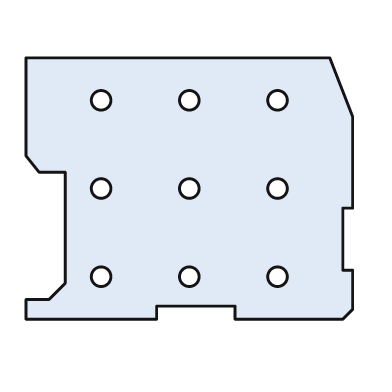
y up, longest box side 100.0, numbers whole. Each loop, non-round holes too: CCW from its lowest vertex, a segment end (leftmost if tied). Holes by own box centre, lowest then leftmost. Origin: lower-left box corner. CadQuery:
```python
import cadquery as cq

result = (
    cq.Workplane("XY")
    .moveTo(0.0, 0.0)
    .lineTo(40.0, 0.0)
    .lineTo(40.0, 4.0)
    .lineTo(64.0, 4.0)
    .lineTo(64.0, 0.0)
    .lineTo(97.0, 0.0)
    .lineTo(100.0, 3.0)
    .lineTo(100.0, 15.0)
    .lineTo(97.0, 15.0)
    .lineTo(97.0, 34.0)
    .lineTo(100.0, 34.0)
    .lineTo(100.0, 62.0)
    .lineTo(93.0, 80.0)
    .lineTo(0.0, 80.0)
    .lineTo(0.0, 50.0)
    .lineTo(4.0, 45.0)
    .lineTo(12.0, 45.0)
    .lineTo(12.0, 11.0)
    .lineTo(7.0, 6.0)
    .lineTo(0.0, 6.0)
    .close()
    .moveTo(23.0, 13.0)
    .circle(3.0)
    .moveTo(50.0, 13.0)
    .circle(3.0)
    .moveTo(77.0, 13.0)
    .circle(3.0)
    .moveTo(23.0, 40.0)
    .circle(3.0)
    .moveTo(50.0, 40.0)
    .circle(3.0)
    .moveTo(77.0, 40.0)
    .circle(3.0)
    .moveTo(23.0, 67.0)
    .circle(3.0)
    .moveTo(50.0, 67.0)
    .circle(3.0)
    .moveTo(77.0, 67.0)
    .circle(3.0)
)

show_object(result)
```